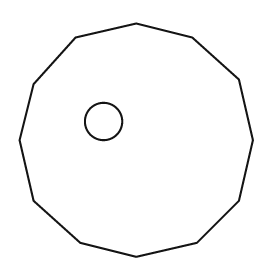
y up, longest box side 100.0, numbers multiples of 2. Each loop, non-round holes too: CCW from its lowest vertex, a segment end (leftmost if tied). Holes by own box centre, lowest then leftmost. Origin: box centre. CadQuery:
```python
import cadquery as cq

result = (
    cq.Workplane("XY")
    .moveTo(0.0, -50.0)
    .lineTo(26.0, -44.0)
    .lineTo(44.0, -26.0)
    .lineTo(50.0, 0.0)
    .lineTo(44.0, 26.0)
    .lineTo(24.0, 44.0)
    .lineTo(0.0, 50.0)
    .lineTo(-26.0, 44.0)
    .lineTo(-44.0, 24.0)
    .lineTo(-50.0, 0.0)
    .lineTo(-44.0, -26.0)
    .lineTo(-24.0, -44.0)
    .close()
    .moveTo(-14.0, 8.0)
    .circle(8.0)
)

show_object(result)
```